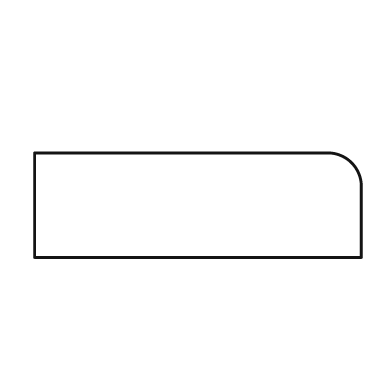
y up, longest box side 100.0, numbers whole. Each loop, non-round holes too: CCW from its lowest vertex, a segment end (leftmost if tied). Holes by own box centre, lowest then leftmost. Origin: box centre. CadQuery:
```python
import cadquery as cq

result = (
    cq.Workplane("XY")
    .moveTo(-50.0, -16.0)
    .lineTo(50.0, -16.0)
    .lineTo(50.0, 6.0)
    .threePointArc((47.0, 13.0), (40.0, 16.0))
    .lineTo(-50.0, 16.0)
    .close()
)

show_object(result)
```